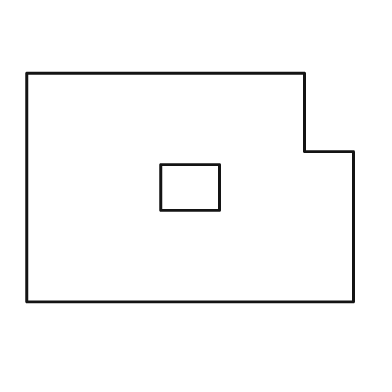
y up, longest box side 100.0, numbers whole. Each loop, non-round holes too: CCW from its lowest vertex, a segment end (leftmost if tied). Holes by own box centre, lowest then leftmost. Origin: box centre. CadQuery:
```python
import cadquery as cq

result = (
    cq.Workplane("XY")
    .moveTo(-50.0, -35.0)
    .lineTo(50.0, -35.0)
    .lineTo(50.0, 11.0)
    .lineTo(35.0, 11.0)
    .lineTo(35.0, 35.0)
    .lineTo(-50.0, 35.0)
    .close()
    .moveTo(-9.0, -7.0)
    .lineTo(9.0, -7.0)
    .lineTo(9.0, 7.0)
    .lineTo(-9.0, 7.0)
    .close()
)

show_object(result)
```